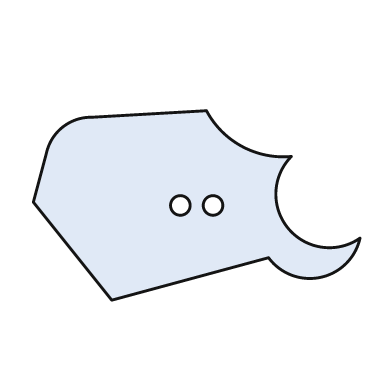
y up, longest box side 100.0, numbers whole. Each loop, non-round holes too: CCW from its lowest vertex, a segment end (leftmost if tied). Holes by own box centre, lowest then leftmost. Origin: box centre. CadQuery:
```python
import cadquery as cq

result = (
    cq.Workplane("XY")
    .moveTo(-26.0, -29.0)
    .lineTo(22.0, -16.0)
    .threePointArc((38.0, -22.0), (50.0, -10.0))
    .threePointArc((28.0, -7.0), (29.0, 15.0))
    .threePointArc((14.0, 18.0), (3.0, 29.0))
    .lineTo(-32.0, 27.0)
    .threePointArc((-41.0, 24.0), (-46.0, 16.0))
    .lineTo(-50.0, 1.0)
    .close()
    .moveTo(-5.0, 0.0)
    .circle(3.0)
    .moveTo(5.0, 0.0)
    .circle(3.0)
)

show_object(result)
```